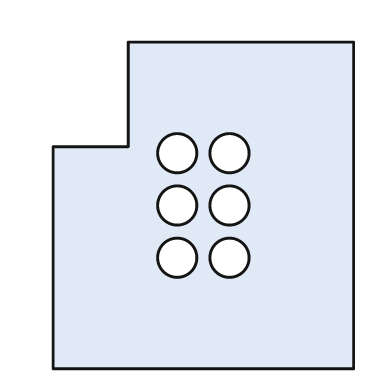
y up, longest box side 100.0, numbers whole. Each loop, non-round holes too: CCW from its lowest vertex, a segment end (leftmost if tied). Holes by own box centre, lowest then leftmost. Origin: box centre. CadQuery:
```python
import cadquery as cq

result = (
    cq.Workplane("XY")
    .moveTo(-46.0, -50.0)
    .lineTo(46.0, -50.0)
    .lineTo(46.0, 50.0)
    .lineTo(-23.0, 50.0)
    .lineTo(-23.0, 18.0)
    .lineTo(-46.0, 18.0)
    .close()
    .moveTo(-8.0, -16.0)
    .circle(6.0)
    .moveTo(8.0, -16.0)
    .circle(6.0)
    .moveTo(-8.0, 0.0)
    .circle(6.0)
    .moveTo(8.0, 0.0)
    .circle(6.0)
    .moveTo(-8.0, 16.0)
    .circle(6.0)
    .moveTo(8.0, 16.0)
    .circle(6.0)
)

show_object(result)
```